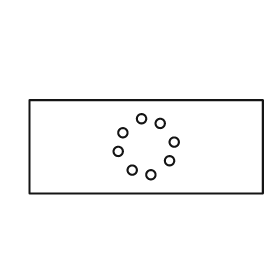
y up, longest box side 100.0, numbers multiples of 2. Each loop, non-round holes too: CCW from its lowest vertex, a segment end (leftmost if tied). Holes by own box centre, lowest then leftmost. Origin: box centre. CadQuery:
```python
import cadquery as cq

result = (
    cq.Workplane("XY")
    .moveTo(-50.0, -20.0)
    .lineTo(50.0, -20.0)
    .lineTo(50.0, 20.0)
    .lineTo(-50.0, 20.0)
    .close()
    .moveTo(2.0, -12.0)
    .circle(2.0)
    .moveTo(-6.0, -10.0)
    .circle(2.0)
    .moveTo(10.0, -6.0)
    .circle(2.0)
    .moveTo(-12.0, -2.0)
    .circle(2.0)
    .moveTo(12.0, 2.0)
    .circle(2.0)
    .moveTo(-10.0, 6.0)
    .circle(2.0)
    .moveTo(6.0, 10.0)
    .circle(2.0)
    .moveTo(-2.0, 12.0)
    .circle(2.0)
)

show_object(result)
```